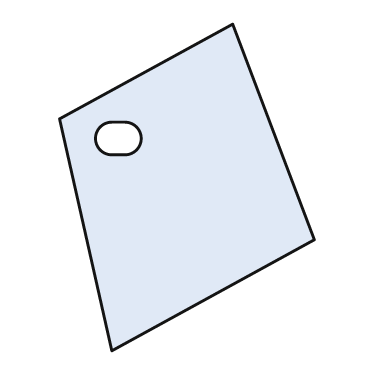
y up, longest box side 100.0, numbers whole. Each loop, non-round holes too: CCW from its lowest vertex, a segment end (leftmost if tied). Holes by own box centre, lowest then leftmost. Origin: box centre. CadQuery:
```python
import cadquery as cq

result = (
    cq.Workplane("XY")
    .moveTo(-23.0, -50.0)
    .lineTo(39.0, -16.0)
    .lineTo(14.0, 50.0)
    .lineTo(-39.0, 21.0)
    .close()
    .moveTo(-23.0, 10.0)
    .lineTo(-19.0, 10.0)
    .threePointArc((-14.0, 15.0), (-19.0, 20.0))
    .lineTo(-23.0, 20.0)
    .threePointArc((-28.0, 15.0), (-23.0, 10.0))
    .close()
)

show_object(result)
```